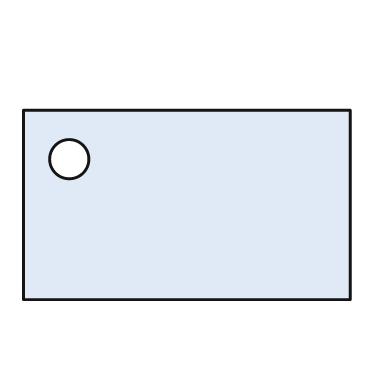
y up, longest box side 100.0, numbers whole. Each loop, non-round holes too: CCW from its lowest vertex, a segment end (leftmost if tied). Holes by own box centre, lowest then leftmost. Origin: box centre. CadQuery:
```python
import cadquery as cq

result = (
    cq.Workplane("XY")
    .moveTo(-50.0, -29.0)
    .lineTo(50.0, -29.0)
    .lineTo(50.0, 29.0)
    .lineTo(-50.0, 29.0)
    .close()
    .moveTo(-36.0, 14.0)
    .circle(6.0)
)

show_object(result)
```